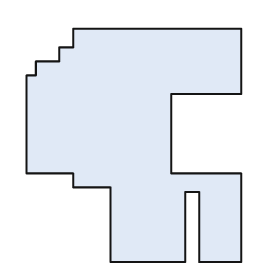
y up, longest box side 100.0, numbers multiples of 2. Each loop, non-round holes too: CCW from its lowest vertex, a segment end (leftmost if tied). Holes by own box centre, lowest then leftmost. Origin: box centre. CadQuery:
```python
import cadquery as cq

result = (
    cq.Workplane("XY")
    .moveTo(-10.0, -50.0)
    .lineTo(22.0, -50.0)
    .lineTo(22.0, -20.0)
    .lineTo(28.0, -20.0)
    .lineTo(28.0, -50.0)
    .lineTo(46.0, -50.0)
    .lineTo(46.0, -12.0)
    .lineTo(16.0, -12.0)
    .lineTo(16.0, 22.0)
    .lineTo(46.0, 22.0)
    .lineTo(46.0, 50.0)
    .lineTo(-26.0, 50.0)
    .lineTo(-26.0, 42.0)
    .lineTo(-32.0, 42.0)
    .lineTo(-32.0, 36.0)
    .lineTo(-42.0, 36.0)
    .lineTo(-42.0, 30.0)
    .lineTo(-46.0, 30.0)
    .lineTo(-46.0, -12.0)
    .lineTo(-26.0, -12.0)
    .lineTo(-26.0, -18.0)
    .lineTo(-10.0, -18.0)
    .close()
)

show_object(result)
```